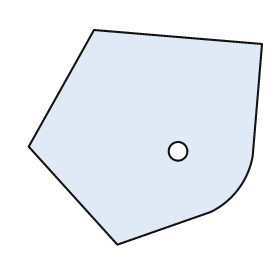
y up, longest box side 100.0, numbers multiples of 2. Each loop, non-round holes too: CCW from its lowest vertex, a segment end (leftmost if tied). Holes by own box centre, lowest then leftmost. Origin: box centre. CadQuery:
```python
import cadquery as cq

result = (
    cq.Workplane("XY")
    .moveTo(-12.0, -46.0)
    .lineTo(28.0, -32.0)
    .threePointArc((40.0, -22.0), (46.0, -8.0))
    .lineTo(50.0, 40.0)
    .lineTo(-22.0, 46.0)
    .lineTo(-50.0, -4.0)
    .close()
    .moveTo(14.0, -6.0)
    .circle(4.0)
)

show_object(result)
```